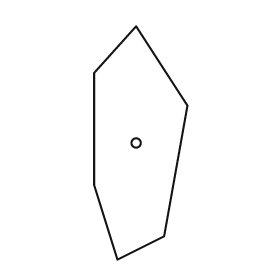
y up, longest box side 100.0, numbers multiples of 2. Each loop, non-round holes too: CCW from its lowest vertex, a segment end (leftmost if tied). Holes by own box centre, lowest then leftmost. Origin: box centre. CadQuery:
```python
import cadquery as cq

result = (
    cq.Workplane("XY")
    .moveTo(-10.0, -50.0)
    .lineTo(10.0, -40.0)
    .lineTo(20.0, 16.0)
    .lineTo(-2.0, 50.0)
    .lineTo(-20.0, 30.0)
    .lineTo(-20.0, -18.0)
    .close()
    .moveTo(-2.0, 0.0)
    .circle(2.0)
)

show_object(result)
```